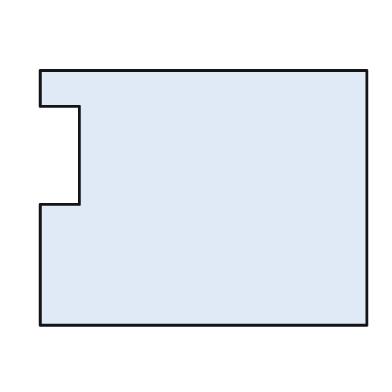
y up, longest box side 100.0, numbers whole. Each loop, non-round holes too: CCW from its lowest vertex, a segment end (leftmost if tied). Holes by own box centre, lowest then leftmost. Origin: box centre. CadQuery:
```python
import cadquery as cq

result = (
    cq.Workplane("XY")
    .moveTo(-50.0, -39.0)
    .lineTo(50.0, -39.0)
    .lineTo(50.0, 39.0)
    .lineTo(-50.0, 39.0)
    .lineTo(-50.0, 28.0)
    .lineTo(-38.0, 28.0)
    .lineTo(-38.0, -2.0)
    .lineTo(-50.0, -2.0)
    .close()
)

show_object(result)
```